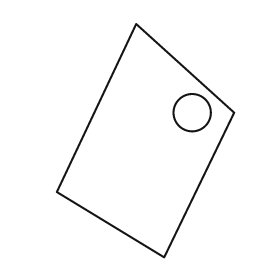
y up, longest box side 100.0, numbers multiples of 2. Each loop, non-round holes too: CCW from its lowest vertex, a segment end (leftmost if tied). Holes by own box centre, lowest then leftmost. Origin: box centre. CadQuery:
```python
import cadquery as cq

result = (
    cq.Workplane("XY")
    .moveTo(8.0, -50.0)
    .lineTo(38.0, 12.0)
    .lineTo(-4.0, 50.0)
    .lineTo(-38.0, -22.0)
    .close()
    .moveTo(20.0, 12.0)
    .circle(8.0)
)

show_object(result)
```